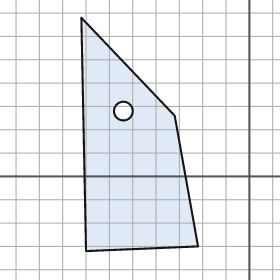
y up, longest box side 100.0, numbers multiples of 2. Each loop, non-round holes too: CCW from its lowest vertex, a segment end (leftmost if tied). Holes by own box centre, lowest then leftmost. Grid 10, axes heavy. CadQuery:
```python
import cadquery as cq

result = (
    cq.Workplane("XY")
    .moveTo(-70.0, -32.0)
    .lineTo(-22.0, -30.0)
    .lineTo(-32.0, 26.0)
    .lineTo(-72.0, 68.0)
    .close()
    .moveTo(-54.0, 28.0)
    .circle(4.0)
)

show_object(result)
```